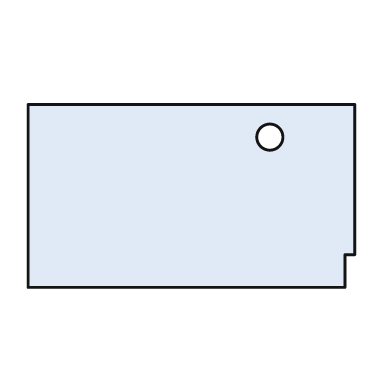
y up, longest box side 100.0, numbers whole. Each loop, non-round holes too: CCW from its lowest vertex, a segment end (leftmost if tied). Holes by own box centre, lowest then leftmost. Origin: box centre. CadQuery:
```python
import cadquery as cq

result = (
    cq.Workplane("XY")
    .moveTo(-50.0, -28.0)
    .lineTo(47.0, -28.0)
    .lineTo(47.0, -18.0)
    .lineTo(50.0, -18.0)
    .lineTo(50.0, 28.0)
    .lineTo(-50.0, 28.0)
    .close()
    .moveTo(24.0, 18.0)
    .circle(4.0)
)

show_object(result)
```